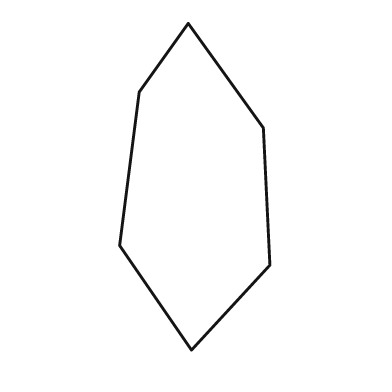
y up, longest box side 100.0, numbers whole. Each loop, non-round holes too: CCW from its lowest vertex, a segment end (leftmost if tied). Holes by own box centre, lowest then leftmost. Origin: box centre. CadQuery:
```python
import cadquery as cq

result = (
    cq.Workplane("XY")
    .moveTo(-1.0, -50.0)
    .lineTo(23.0, -24.0)
    .lineTo(21.0, 18.0)
    .lineTo(-2.0, 50.0)
    .lineTo(-17.0, 29.0)
    .lineTo(-23.0, -18.0)
    .close()
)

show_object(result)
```